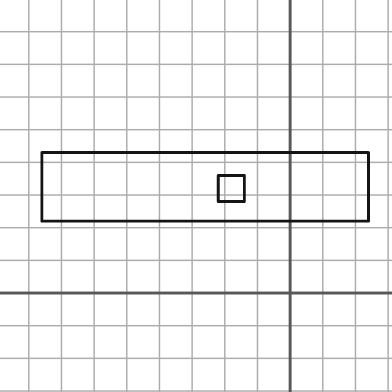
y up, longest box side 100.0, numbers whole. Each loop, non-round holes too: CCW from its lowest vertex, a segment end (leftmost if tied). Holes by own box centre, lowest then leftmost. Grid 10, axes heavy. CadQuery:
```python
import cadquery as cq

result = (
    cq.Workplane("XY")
    .moveTo(-76.0, 22.0)
    .lineTo(24.0, 22.0)
    .lineTo(24.0, 43.0)
    .lineTo(-76.0, 43.0)
    .close()
    .moveTo(-22.0, 28.0)
    .lineTo(-14.0, 28.0)
    .lineTo(-14.0, 36.0)
    .lineTo(-22.0, 36.0)
    .close()
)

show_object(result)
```